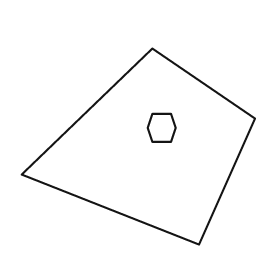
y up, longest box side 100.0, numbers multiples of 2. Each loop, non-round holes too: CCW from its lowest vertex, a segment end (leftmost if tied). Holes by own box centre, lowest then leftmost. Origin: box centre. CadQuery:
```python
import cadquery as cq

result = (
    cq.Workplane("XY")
    .moveTo(26.0, -42.0)
    .lineTo(50.0, 12.0)
    .lineTo(6.0, 42.0)
    .lineTo(-50.0, -12.0)
    .close()
    .moveTo(6.0, 2.0)
    .lineTo(14.0, 2.0)
    .lineTo(16.0, 8.0)
    .lineTo(14.0, 14.0)
    .lineTo(6.0, 14.0)
    .lineTo(4.0, 8.0)
    .close()
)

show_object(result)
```